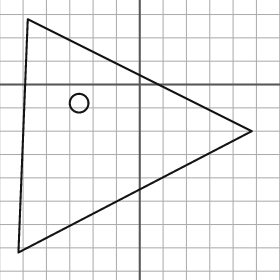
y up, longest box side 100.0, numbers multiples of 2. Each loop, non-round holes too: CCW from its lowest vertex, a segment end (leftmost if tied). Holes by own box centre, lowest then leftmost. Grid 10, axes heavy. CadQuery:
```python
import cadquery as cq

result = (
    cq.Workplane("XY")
    .moveTo(-52.0, -72.0)
    .lineTo(48.0, -20.0)
    .lineTo(-48.0, 28.0)
    .close()
    .moveTo(-26.0, -8.0)
    .circle(4.0)
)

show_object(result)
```